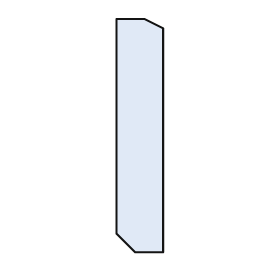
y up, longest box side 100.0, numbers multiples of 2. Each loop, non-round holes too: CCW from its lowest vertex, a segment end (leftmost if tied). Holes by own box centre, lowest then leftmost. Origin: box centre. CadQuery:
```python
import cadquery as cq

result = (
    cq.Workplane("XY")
    .moveTo(-2.0, -50.0)
    .lineTo(10.0, -50.0)
    .lineTo(10.0, 46.0)
    .lineTo(2.0, 50.0)
    .lineTo(-10.0, 50.0)
    .lineTo(-10.0, -42.0)
    .close()
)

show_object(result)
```